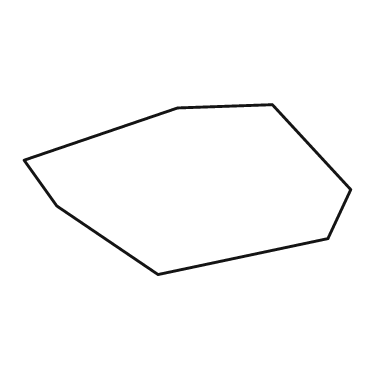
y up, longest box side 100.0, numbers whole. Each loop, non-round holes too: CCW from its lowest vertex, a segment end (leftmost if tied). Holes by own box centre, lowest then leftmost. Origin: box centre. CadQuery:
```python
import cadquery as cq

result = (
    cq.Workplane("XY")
    .moveTo(-9.0, -26.0)
    .lineTo(43.0, -15.0)
    .lineTo(50.0, 0.0)
    .lineTo(26.0, 26.0)
    .lineTo(-3.0, 25.0)
    .lineTo(-50.0, 9.0)
    .lineTo(-40.0, -5.0)
    .close()
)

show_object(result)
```